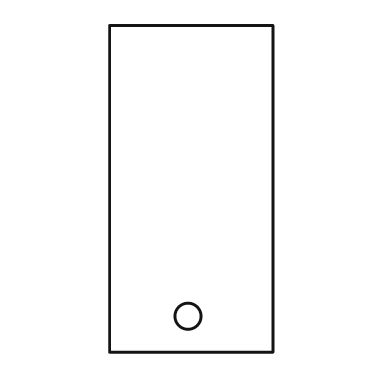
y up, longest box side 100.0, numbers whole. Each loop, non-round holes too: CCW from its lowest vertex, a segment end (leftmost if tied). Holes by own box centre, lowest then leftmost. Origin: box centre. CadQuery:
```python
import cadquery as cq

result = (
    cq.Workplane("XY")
    .moveTo(-25.0, -50.0)
    .lineTo(25.0, -50.0)
    .lineTo(25.0, 50.0)
    .lineTo(-25.0, 50.0)
    .close()
    .moveTo(-1.0, -39.0)
    .circle(4.0)
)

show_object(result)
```